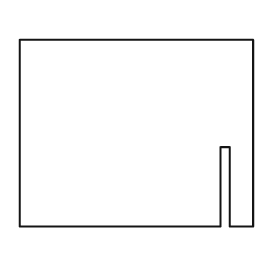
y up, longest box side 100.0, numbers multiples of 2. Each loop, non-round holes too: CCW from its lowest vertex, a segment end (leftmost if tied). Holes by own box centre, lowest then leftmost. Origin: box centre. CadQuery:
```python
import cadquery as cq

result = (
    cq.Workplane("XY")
    .moveTo(-50.0, -40.0)
    .lineTo(36.0, -40.0)
    .lineTo(36.0, -6.0)
    .lineTo(40.0, -6.0)
    .lineTo(40.0, -40.0)
    .lineTo(50.0, -40.0)
    .lineTo(50.0, 40.0)
    .lineTo(-50.0, 40.0)
    .close()
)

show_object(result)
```